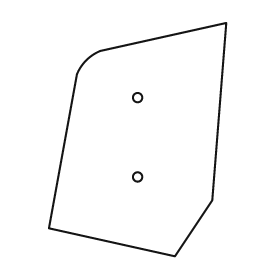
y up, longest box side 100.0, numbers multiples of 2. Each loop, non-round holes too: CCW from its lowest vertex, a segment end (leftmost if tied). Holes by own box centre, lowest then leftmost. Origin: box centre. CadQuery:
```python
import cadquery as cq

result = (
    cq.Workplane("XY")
    .moveTo(16.0, -50.0)
    .lineTo(32.0, -26.0)
    .lineTo(38.0, 50.0)
    .lineTo(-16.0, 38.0)
    .threePointArc((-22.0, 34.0), (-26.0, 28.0))
    .lineTo(-38.0, -38.0)
    .close()
    .moveTo(0.0, -16.0)
    .circle(2.0)
    .moveTo(0.0, 18.0)
    .circle(2.0)
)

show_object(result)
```